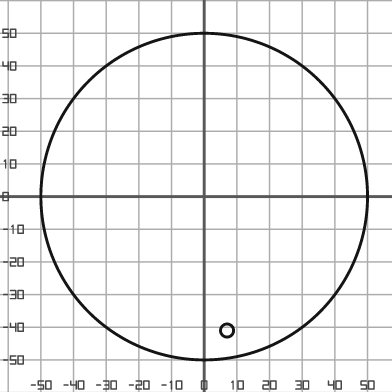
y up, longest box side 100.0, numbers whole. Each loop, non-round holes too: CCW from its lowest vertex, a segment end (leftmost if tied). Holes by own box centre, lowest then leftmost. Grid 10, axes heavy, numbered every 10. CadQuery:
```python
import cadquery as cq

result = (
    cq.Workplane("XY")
    .moveTo(0.0, 0.0)
    .circle(50.0)
    .moveTo(7.0, -41.0)
    .circle(2.0)
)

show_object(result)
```